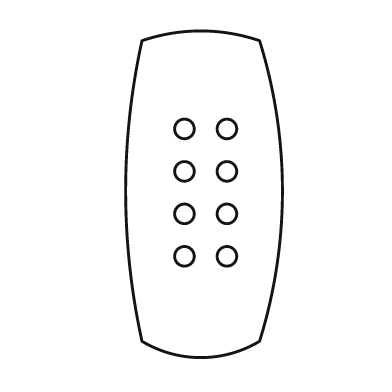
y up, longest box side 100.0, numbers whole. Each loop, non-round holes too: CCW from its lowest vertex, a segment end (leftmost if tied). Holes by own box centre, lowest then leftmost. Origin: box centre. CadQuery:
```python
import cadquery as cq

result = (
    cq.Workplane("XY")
    .moveTo(-19.0, -45.0)
    .threePointArc((-1.0, -50.0), (17.0, -45.0))
    .threePointArc((24.0, 1.0), (17.0, 47.0))
    .threePointArc((-1.0, 50.0), (-19.0, 47.0))
    .threePointArc((-24.0, 1.0), (-19.0, -45.0))
    .close()
    .moveTo(-6.0, -19.0)
    .circle(3.0)
    .moveTo(7.0, -19.0)
    .circle(3.0)
    .moveTo(-6.0, -6.0)
    .circle(3.0)
    .moveTo(7.0, -6.0)
    .circle(3.0)
    .moveTo(-6.0, 7.0)
    .circle(3.0)
    .moveTo(7.0, 7.0)
    .circle(3.0)
    .moveTo(-6.0, 20.0)
    .circle(3.0)
    .moveTo(7.0, 20.0)
    .circle(3.0)
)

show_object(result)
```